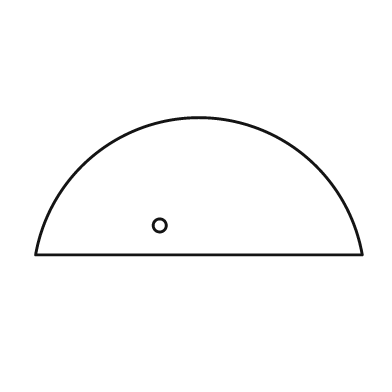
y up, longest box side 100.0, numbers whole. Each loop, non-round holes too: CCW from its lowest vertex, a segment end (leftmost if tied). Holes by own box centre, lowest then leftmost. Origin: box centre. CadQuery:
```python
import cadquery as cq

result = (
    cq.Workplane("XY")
    .moveTo(-50.0, -21.0)
    .lineTo(50.0, -21.0)
    .threePointArc((0.0, 21.0), (-50.0, -21.0))
    .close()
    .moveTo(-12.0, -12.0)
    .circle(2.0)
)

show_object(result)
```